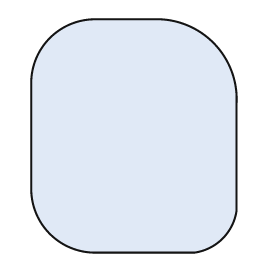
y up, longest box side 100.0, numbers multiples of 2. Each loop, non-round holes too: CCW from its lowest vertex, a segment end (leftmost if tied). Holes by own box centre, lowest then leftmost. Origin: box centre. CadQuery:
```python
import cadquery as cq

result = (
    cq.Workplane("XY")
    .moveTo(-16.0, -50.0)
    .lineTo(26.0, -50.0)
    .threePointArc((38.0, -44.0), (44.0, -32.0))
    .lineTo(44.0, 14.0)
    .threePointArc((34.0, 40.0), (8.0, 50.0))
    .lineTo(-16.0, 50.0)
    .threePointArc((-36.0, 42.0), (-44.0, 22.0))
    .lineTo(-44.0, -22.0)
    .threePointArc((-36.0, -42.0), (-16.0, -50.0))
    .close()
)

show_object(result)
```